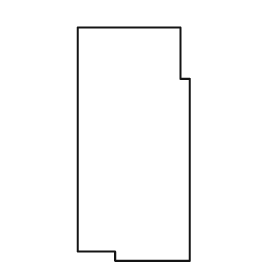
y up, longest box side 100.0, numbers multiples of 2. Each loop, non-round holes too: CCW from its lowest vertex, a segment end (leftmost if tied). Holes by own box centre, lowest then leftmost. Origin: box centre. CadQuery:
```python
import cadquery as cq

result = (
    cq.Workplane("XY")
    .moveTo(-8.0, -50.0)
    .lineTo(24.0, -50.0)
    .lineTo(24.0, 28.0)
    .lineTo(20.0, 28.0)
    .lineTo(20.0, 50.0)
    .lineTo(-24.0, 50.0)
    .lineTo(-24.0, -46.0)
    .lineTo(-8.0, -46.0)
    .close()
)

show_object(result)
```